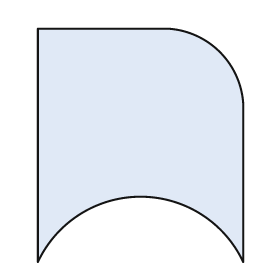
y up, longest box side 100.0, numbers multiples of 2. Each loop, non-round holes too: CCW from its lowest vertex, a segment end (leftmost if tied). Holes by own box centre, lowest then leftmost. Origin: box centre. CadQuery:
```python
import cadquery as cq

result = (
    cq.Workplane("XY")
    .moveTo(-44.0, -50.0)
    .threePointArc((0.0, -22.0), (44.0, -50.0))
    .lineTo(44.0, 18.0)
    .threePointArc((34.0, 40.0), (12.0, 50.0))
    .lineTo(-44.0, 50.0)
    .close()
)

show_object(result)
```